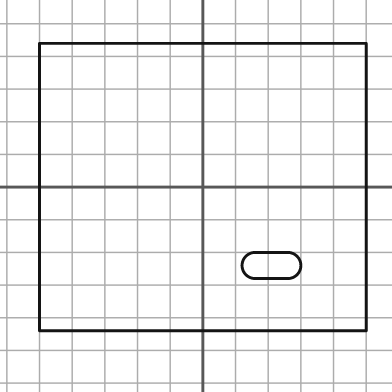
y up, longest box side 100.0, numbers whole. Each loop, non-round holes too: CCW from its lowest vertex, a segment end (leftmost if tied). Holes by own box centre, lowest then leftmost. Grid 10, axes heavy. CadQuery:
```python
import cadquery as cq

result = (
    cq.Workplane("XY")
    .moveTo(-50.0, -44.0)
    .lineTo(50.0, -44.0)
    .lineTo(50.0, 44.0)
    .lineTo(-50.0, 44.0)
    .close()
    .moveTo(16.0, -28.0)
    .lineTo(26.0, -28.0)
    .threePointArc((30.0, -24.0), (26.0, -20.0))
    .lineTo(16.0, -20.0)
    .threePointArc((12.0, -24.0), (16.0, -28.0))
    .close()
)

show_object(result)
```